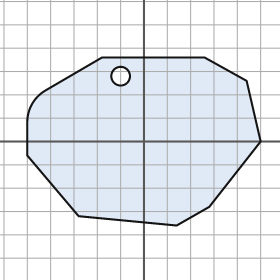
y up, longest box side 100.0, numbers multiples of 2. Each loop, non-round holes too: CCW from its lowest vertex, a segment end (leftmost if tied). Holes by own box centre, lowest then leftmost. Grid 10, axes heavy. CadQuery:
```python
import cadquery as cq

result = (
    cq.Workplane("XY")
    .moveTo(14.0, -36.0)
    .lineTo(28.0, -28.0)
    .lineTo(50.0, 0.0)
    .lineTo(44.0, 26.0)
    .lineTo(26.0, 36.0)
    .lineTo(-18.0, 36.0)
    .lineTo(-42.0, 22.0)
    .threePointArc((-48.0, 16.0), (-50.0, 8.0))
    .lineTo(-50.0, -6.0)
    .lineTo(-28.0, -32.0)
    .close()
    .moveTo(-10.0, 28.0)
    .circle(4.0)
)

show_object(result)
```